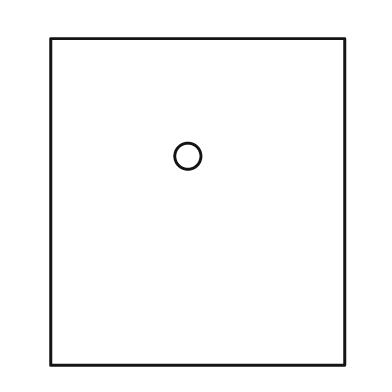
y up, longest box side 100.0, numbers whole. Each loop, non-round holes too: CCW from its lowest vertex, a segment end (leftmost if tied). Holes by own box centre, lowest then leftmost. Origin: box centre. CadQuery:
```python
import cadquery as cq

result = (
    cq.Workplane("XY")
    .moveTo(-45.0, -50.0)
    .lineTo(45.0, -50.0)
    .lineTo(45.0, 50.0)
    .lineTo(-45.0, 50.0)
    .close()
    .moveTo(-3.0, 14.0)
    .circle(4.0)
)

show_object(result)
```